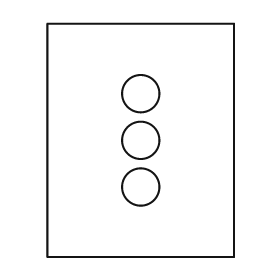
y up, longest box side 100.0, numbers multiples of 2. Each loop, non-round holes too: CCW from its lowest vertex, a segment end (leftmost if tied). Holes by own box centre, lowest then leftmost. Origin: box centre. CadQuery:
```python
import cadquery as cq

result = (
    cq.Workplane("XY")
    .moveTo(-40.0, -50.0)
    .lineTo(40.0, -50.0)
    .lineTo(40.0, 50.0)
    .lineTo(-40.0, 50.0)
    .close()
    .moveTo(0.0, -20.0)
    .circle(8.0)
    .moveTo(0.0, 0.0)
    .circle(8.0)
    .moveTo(0.0, 20.0)
    .circle(8.0)
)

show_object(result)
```